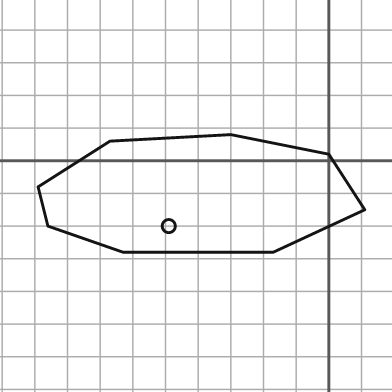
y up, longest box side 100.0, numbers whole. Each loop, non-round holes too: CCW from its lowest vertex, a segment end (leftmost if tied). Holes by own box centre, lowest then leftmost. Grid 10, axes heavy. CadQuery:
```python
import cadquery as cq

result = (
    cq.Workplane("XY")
    .moveTo(-63.0, -28.0)
    .lineTo(-17.0, -28.0)
    .lineTo(11.0, -15.0)
    .lineTo(0.0, 2.0)
    .lineTo(-30.0, 8.0)
    .lineTo(-67.0, 6.0)
    .lineTo(-89.0, -8.0)
    .lineTo(-86.0, -20.0)
    .close()
    .moveTo(-49.0, -20.0)
    .circle(2.0)
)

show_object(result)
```